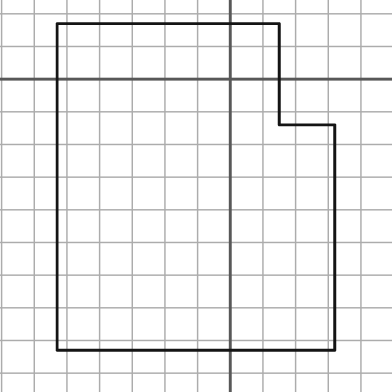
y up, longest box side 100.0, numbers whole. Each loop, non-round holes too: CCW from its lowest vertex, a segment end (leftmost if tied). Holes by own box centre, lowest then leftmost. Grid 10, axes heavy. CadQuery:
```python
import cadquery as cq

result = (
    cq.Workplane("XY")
    .moveTo(-53.0, -83.0)
    .lineTo(32.0, -83.0)
    .lineTo(32.0, -14.0)
    .lineTo(15.0, -14.0)
    .lineTo(15.0, 17.0)
    .lineTo(-53.0, 17.0)
    .close()
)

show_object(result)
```